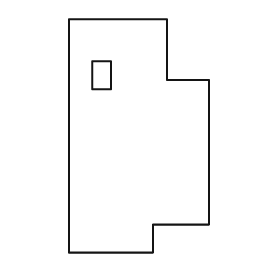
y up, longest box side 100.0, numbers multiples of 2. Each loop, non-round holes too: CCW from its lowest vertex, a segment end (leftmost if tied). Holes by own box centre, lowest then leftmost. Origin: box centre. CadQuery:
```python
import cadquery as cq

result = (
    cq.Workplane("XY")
    .moveTo(-30.0, -50.0)
    .lineTo(6.0, -50.0)
    .lineTo(6.0, -38.0)
    .lineTo(30.0, -38.0)
    .lineTo(30.0, 24.0)
    .lineTo(12.0, 24.0)
    .lineTo(12.0, 50.0)
    .lineTo(-30.0, 50.0)
    .close()
    .moveTo(-20.0, 20.0)
    .lineTo(-12.0, 20.0)
    .lineTo(-12.0, 32.0)
    .lineTo(-20.0, 32.0)
    .close()
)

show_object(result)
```